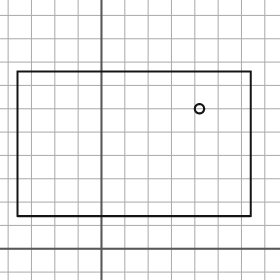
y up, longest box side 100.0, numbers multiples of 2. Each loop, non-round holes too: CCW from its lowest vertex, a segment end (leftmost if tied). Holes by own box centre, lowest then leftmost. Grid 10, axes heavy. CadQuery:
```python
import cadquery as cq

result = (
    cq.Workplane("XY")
    .moveTo(-36.0, 14.0)
    .lineTo(64.0, 14.0)
    .lineTo(64.0, 76.0)
    .lineTo(-36.0, 76.0)
    .close()
    .moveTo(42.0, 60.0)
    .circle(2.0)
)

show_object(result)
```